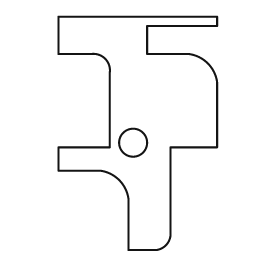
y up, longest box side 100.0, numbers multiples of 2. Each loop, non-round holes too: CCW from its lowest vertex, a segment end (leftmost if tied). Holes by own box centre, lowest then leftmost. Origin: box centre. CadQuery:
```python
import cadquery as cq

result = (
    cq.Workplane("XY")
    .moveTo(-4.0, -50.0)
    .lineTo(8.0, -50.0)
    .threePointArc((12.0, -48.0), (14.0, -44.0))
    .lineTo(14.0, -6.0)
    .lineTo(34.0, -6.0)
    .lineTo(34.0, 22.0)
    .threePointArc((30.0, 30.0), (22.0, 34.0))
    .lineTo(4.0, 34.0)
    .lineTo(4.0, 46.0)
    .lineTo(34.0, 46.0)
    .lineTo(34.0, 50.0)
    .lineTo(-34.0, 50.0)
    .lineTo(-34.0, 34.0)
    .lineTo(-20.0, 34.0)
    .threePointArc((-14.0, 32.0), (-12.0, 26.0))
    .lineTo(-12.0, -6.0)
    .lineTo(-34.0, -6.0)
    .lineTo(-34.0, -16.0)
    .lineTo(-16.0, -16.0)
    .threePointArc((-8.0, -20.0), (-4.0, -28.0))
    .close()
    .moveTo(-2.0, -4.0)
    .circle(6.0)
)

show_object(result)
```